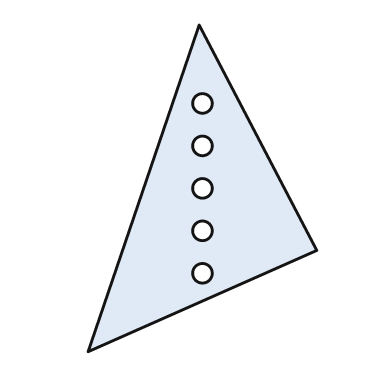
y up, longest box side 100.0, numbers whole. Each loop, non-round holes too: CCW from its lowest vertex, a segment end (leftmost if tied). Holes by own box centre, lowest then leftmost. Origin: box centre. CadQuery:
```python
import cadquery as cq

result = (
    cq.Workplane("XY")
    .moveTo(-35.0, -50.0)
    .lineTo(35.0, -19.0)
    .lineTo(-1.0, 50.0)
    .close()
    .moveTo(0.0, -26.0)
    .circle(3.0)
    .moveTo(0.0, -13.0)
    .circle(3.0)
    .moveTo(0.0, 0.0)
    .circle(3.0)
    .moveTo(0.0, 13.0)
    .circle(3.0)
    .moveTo(0.0, 26.0)
    .circle(3.0)
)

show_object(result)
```